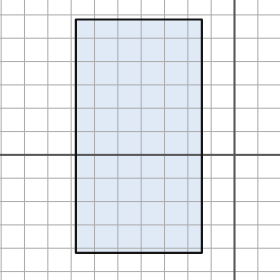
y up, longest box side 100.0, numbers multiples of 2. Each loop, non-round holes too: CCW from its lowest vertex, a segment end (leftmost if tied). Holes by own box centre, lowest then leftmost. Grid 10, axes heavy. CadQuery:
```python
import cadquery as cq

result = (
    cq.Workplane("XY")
    .moveTo(-68.0, -42.0)
    .lineTo(-14.0, -42.0)
    .lineTo(-14.0, 58.0)
    .lineTo(-68.0, 58.0)
    .close()
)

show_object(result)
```